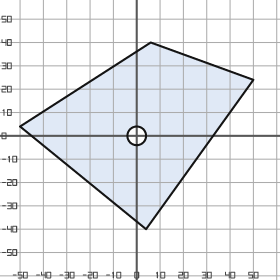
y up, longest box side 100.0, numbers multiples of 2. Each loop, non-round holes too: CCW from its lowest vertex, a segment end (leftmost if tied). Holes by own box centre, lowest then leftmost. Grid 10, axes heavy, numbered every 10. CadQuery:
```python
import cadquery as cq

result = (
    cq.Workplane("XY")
    .moveTo(4.0, -40.0)
    .lineTo(50.0, 24.0)
    .lineTo(6.0, 40.0)
    .lineTo(-50.0, 4.0)
    .close()
    .moveTo(0.0, 0.0)
    .circle(4.0)
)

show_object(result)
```